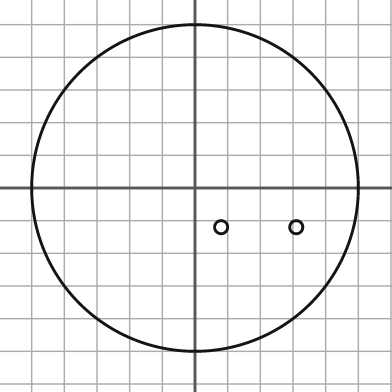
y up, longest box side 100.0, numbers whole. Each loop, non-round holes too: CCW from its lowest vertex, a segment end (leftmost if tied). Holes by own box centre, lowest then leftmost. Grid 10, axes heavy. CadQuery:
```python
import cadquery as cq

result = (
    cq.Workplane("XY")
    .moveTo(0.0, 0.0)
    .circle(50.0)
    .moveTo(8.0, -12.0)
    .circle(2.0)
    .moveTo(31.0, -12.0)
    .circle(2.0)
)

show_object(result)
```